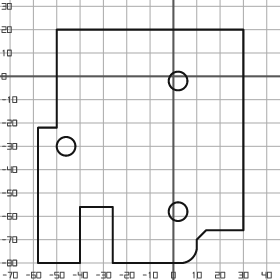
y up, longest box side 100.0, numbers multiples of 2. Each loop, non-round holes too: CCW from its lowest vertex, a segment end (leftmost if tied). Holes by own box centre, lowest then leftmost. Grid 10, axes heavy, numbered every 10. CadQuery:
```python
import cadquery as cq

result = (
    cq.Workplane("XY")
    .moveTo(-58.0, -80.0)
    .lineTo(-40.0, -80.0)
    .lineTo(-40.0, -56.0)
    .lineTo(-26.0, -56.0)
    .lineTo(-26.0, -80.0)
    .lineTo(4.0, -80.0)
    .threePointArc((8.0, -78.0), (10.0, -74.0))
    .lineTo(10.0, -70.0)
    .lineTo(14.0, -66.0)
    .lineTo(30.0, -66.0)
    .lineTo(30.0, 20.0)
    .lineTo(-50.0, 20.0)
    .lineTo(-50.0, -22.0)
    .lineTo(-58.0, -22.0)
    .close()
    .moveTo(2.0, -58.0)
    .circle(4.0)
    .moveTo(-46.0, -30.0)
    .circle(4.0)
    .moveTo(2.0, -2.0)
    .circle(4.0)
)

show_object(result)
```